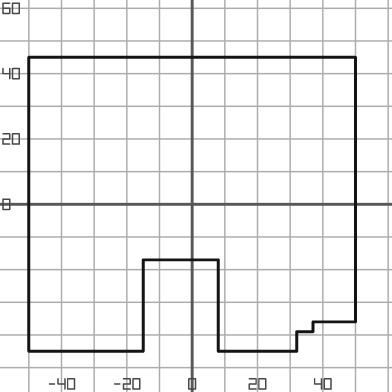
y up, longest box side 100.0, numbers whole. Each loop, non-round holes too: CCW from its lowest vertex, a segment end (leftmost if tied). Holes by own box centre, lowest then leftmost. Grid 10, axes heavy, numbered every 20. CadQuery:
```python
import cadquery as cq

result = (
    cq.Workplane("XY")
    .moveTo(-50.0, -45.0)
    .lineTo(-15.0, -45.0)
    .lineTo(-15.0, -17.0)
    .lineTo(8.0, -17.0)
    .lineTo(8.0, -45.0)
    .lineTo(32.0, -45.0)
    .lineTo(32.0, -39.0)
    .lineTo(37.0, -39.0)
    .lineTo(37.0, -36.0)
    .lineTo(50.0, -36.0)
    .lineTo(50.0, 45.0)
    .lineTo(-50.0, 45.0)
    .close()
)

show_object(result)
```